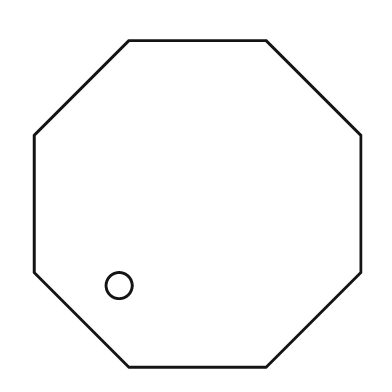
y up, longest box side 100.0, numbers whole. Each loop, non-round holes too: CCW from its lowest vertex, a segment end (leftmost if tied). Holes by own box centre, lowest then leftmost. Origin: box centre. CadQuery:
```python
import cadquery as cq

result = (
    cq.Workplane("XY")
    .moveTo(-21.0, -50.0)
    .lineTo(21.0, -50.0)
    .lineTo(50.0, -21.0)
    .lineTo(50.0, 21.0)
    .lineTo(21.0, 50.0)
    .lineTo(-21.0, 50.0)
    .lineTo(-50.0, 21.0)
    .lineTo(-50.0, -21.0)
    .close()
    .moveTo(-24.0, -25.0)
    .circle(4.0)
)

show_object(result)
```